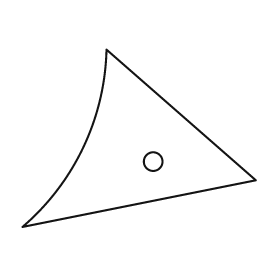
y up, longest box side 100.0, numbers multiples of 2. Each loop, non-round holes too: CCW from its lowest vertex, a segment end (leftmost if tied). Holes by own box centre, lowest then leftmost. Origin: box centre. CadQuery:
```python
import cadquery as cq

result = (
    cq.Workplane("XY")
    .moveTo(-50.0, -38.0)
    .lineTo(50.0, -18.0)
    .lineTo(-14.0, 38.0)
    .threePointArc((-24.0, -4.0), (-50.0, -38.0))
    .close()
    .moveTo(6.0, -10.0)
    .circle(4.0)
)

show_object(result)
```